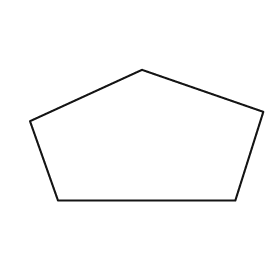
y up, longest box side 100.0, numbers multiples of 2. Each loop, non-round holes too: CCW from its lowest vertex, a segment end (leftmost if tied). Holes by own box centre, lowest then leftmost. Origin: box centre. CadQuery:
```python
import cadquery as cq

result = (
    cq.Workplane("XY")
    .moveTo(-38.0, -28.0)
    .lineTo(38.0, -28.0)
    .lineTo(50.0, 10.0)
    .lineTo(-2.0, 28.0)
    .lineTo(-50.0, 6.0)
    .close()
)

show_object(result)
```